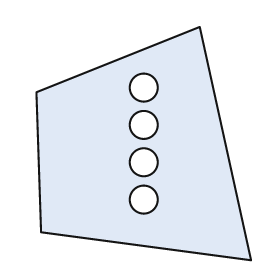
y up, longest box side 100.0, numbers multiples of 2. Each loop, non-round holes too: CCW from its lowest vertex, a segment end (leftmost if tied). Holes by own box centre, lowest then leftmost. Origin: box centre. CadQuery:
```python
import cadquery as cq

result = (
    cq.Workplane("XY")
    .moveTo(46.0, -50.0)
    .lineTo(24.0, 50.0)
    .lineTo(-46.0, 22.0)
    .lineTo(-44.0, -38.0)
    .close()
    .moveTo(0.0, -24.0)
    .circle(6.0)
    .moveTo(0.0, -8.0)
    .circle(6.0)
    .moveTo(0.0, 8.0)
    .circle(6.0)
    .moveTo(0.0, 24.0)
    .circle(6.0)
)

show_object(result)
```